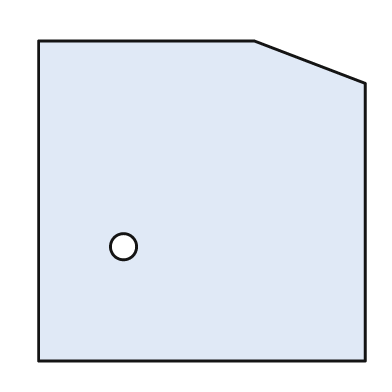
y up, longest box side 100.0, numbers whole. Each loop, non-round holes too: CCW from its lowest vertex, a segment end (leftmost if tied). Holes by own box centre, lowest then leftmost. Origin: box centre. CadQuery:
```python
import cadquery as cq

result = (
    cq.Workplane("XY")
    .moveTo(-50.0, -49.0)
    .lineTo(50.0, -49.0)
    .lineTo(50.0, 36.0)
    .lineTo(16.0, 49.0)
    .lineTo(-50.0, 49.0)
    .close()
    .moveTo(-24.0, -14.0)
    .circle(4.0)
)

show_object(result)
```